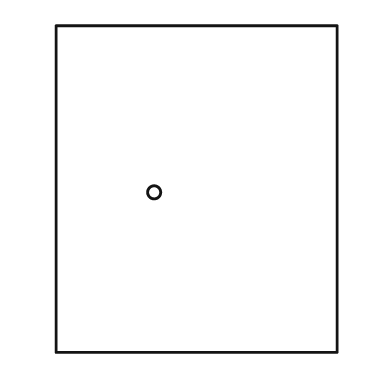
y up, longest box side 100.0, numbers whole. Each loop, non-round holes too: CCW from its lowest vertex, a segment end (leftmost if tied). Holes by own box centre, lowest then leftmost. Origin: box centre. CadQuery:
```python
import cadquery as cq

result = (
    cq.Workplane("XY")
    .moveTo(-43.0, -50.0)
    .lineTo(43.0, -50.0)
    .lineTo(43.0, 50.0)
    .lineTo(-43.0, 50.0)
    .close()
    .moveTo(-13.0, -1.0)
    .circle(2.0)
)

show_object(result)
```